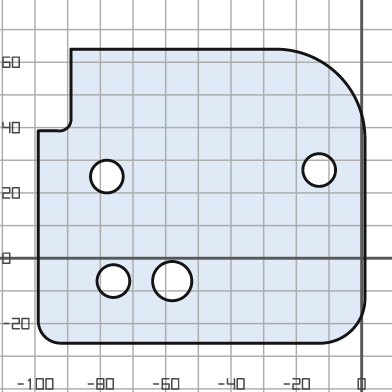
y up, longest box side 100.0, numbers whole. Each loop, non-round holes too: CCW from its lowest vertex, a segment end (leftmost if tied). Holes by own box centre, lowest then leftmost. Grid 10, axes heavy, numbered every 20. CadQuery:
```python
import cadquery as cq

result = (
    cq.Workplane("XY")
    .moveTo(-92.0, -26.0)
    .lineTo(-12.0, -26.0)
    .threePointArc((-3.0, -22.0), (1.0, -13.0))
    .lineTo(1.0, 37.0)
    .threePointArc((-7.0, 56.0), (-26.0, 64.0))
    .lineTo(-89.0, 64.0)
    .lineTo(-89.0, 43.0)
    .threePointArc((-90.0, 40.0), (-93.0, 39.0))
    .lineTo(-99.0, 39.0)
    .lineTo(-99.0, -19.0)
    .threePointArc((-97.0, -24.0), (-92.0, -26.0))
    .close()
    .moveTo(-76.0, -7.0)
    .circle(5.0)
    .moveTo(-58.0, -7.0)
    .circle(6.0)
    .moveTo(-78.0, 25.0)
    .circle(5.0)
    .moveTo(-13.0, 27.0)
    .circle(5.0)
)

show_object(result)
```